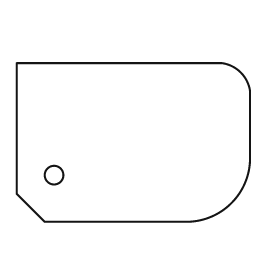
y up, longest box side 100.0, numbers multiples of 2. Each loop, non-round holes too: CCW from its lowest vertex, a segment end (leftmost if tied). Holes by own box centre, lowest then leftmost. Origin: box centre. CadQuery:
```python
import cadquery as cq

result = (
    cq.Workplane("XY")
    .moveTo(-38.0, -34.0)
    .lineTo(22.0, -34.0)
    .threePointArc((42.0, -26.0), (50.0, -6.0))
    .lineTo(50.0, 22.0)
    .threePointArc((46.0, 30.0), (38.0, 34.0))
    .lineTo(-50.0, 34.0)
    .lineTo(-50.0, -22.0)
    .close()
    .moveTo(-34.0, -14.0)
    .circle(4.0)
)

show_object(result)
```